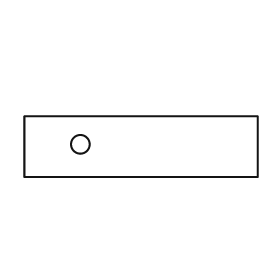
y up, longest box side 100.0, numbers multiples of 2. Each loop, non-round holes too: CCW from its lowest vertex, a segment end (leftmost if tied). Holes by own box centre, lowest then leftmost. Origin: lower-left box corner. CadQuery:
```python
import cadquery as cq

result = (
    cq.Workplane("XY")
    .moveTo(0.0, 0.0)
    .lineTo(100.0, 0.0)
    .lineTo(100.0, 26.0)
    .lineTo(0.0, 26.0)
    .close()
    .moveTo(24.0, 14.0)
    .circle(4.0)
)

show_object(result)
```